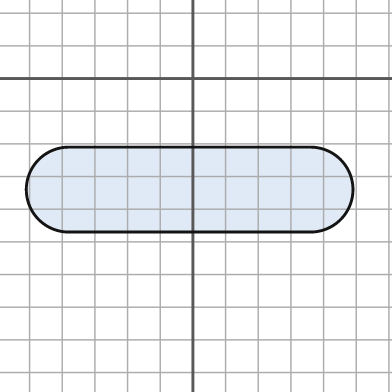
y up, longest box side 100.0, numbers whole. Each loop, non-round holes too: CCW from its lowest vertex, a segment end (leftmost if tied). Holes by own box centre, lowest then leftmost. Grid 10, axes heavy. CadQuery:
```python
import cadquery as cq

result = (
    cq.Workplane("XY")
    .moveTo(-38.0, -47.0)
    .lineTo(36.0, -47.0)
    .threePointArc((49.0, -34.0), (36.0, -21.0))
    .lineTo(-38.0, -21.0)
    .threePointArc((-51.0, -34.0), (-38.0, -47.0))
    .close()
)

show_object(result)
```